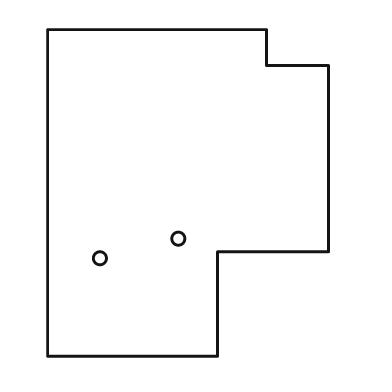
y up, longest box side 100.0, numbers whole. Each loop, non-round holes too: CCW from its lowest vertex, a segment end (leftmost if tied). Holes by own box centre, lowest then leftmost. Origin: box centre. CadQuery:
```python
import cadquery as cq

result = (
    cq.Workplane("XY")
    .moveTo(-43.0, -50.0)
    .lineTo(9.0, -50.0)
    .lineTo(9.0, -18.0)
    .lineTo(43.0, -18.0)
    .lineTo(43.0, 39.0)
    .lineTo(24.0, 39.0)
    .lineTo(24.0, 50.0)
    .lineTo(-43.0, 50.0)
    .close()
    .moveTo(-27.0, -20.0)
    .circle(2.0)
    .moveTo(-3.0, -14.0)
    .circle(2.0)
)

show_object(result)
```